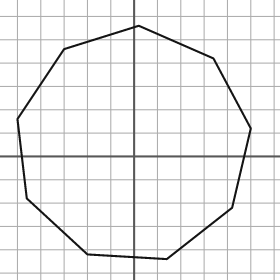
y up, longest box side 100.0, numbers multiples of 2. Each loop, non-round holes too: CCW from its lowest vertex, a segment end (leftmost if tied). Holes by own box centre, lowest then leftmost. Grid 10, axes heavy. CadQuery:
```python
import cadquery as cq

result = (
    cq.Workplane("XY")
    .moveTo(14.0, -44.0)
    .lineTo(42.0, -22.0)
    .lineTo(50.0, 12.0)
    .lineTo(34.0, 42.0)
    .lineTo(2.0, 56.0)
    .lineTo(-30.0, 46.0)
    .lineTo(-50.0, 16.0)
    .lineTo(-46.0, -18.0)
    .lineTo(-20.0, -42.0)
    .close()
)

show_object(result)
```